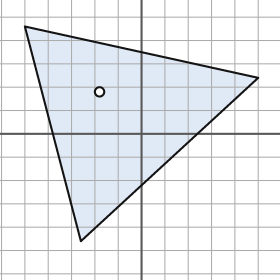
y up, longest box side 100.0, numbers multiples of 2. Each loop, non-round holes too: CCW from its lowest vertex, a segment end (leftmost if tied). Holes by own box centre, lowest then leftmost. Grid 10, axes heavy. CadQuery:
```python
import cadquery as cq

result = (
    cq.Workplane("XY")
    .moveTo(-26.0, -46.0)
    .lineTo(50.0, 24.0)
    .lineTo(-50.0, 46.0)
    .close()
    .moveTo(-18.0, 18.0)
    .circle(2.0)
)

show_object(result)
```